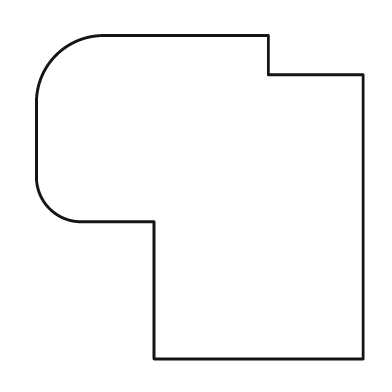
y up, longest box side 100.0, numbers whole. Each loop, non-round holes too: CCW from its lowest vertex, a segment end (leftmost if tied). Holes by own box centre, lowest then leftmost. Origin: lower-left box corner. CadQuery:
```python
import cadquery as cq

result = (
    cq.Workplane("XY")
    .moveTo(36.0, 0.0)
    .lineTo(100.0, 0.0)
    .lineTo(100.0, 87.0)
    .lineTo(71.0, 87.0)
    .lineTo(71.0, 99.0)
    .lineTo(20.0, 99.0)
    .threePointArc((6.0, 93.0), (0.0, 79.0))
    .lineTo(0.0, 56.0)
    .threePointArc((4.0, 46.0), (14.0, 42.0))
    .lineTo(36.0, 42.0)
    .close()
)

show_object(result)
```